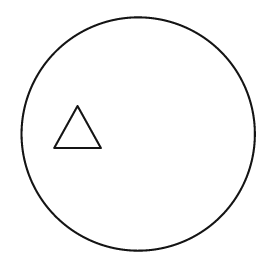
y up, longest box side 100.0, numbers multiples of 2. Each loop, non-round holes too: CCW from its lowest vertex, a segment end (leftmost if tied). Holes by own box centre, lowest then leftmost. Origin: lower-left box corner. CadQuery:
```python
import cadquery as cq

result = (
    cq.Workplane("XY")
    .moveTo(50.0, 50.0)
    .circle(50.0)
    .moveTo(14.0, 44.0)
    .lineTo(34.0, 44.0)
    .lineTo(24.0, 62.0)
    .close()
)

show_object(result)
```